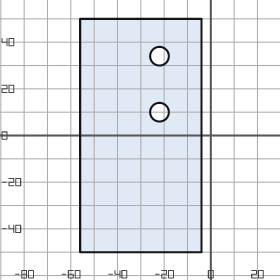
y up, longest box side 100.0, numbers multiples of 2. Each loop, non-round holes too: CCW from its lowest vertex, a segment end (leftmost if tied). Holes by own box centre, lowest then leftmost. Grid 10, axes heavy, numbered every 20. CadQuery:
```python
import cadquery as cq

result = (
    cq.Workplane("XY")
    .moveTo(-56.0, -50.0)
    .lineTo(-4.0, -50.0)
    .lineTo(-4.0, 50.0)
    .lineTo(-56.0, 50.0)
    .close()
    .moveTo(-22.0, 10.0)
    .circle(4.0)
    .moveTo(-22.0, 34.0)
    .circle(4.0)
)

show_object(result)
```